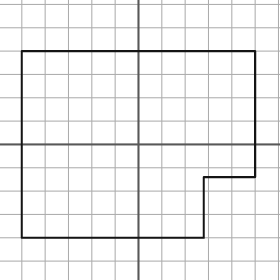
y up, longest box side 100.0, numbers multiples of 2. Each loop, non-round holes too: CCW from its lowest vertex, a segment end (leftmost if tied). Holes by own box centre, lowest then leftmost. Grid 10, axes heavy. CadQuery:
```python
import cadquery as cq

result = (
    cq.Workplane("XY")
    .moveTo(-50.0, -40.0)
    .lineTo(28.0, -40.0)
    .lineTo(28.0, -14.0)
    .lineTo(50.0, -14.0)
    .lineTo(50.0, 40.0)
    .lineTo(-50.0, 40.0)
    .close()
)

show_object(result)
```